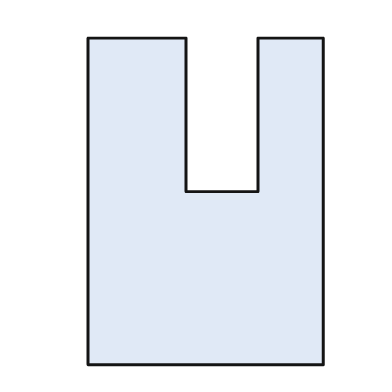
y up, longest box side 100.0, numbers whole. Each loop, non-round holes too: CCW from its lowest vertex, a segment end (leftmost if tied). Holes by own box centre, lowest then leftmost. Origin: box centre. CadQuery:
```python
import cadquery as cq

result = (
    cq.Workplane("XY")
    .moveTo(-36.0, -50.0)
    .lineTo(36.0, -50.0)
    .lineTo(36.0, 50.0)
    .lineTo(16.0, 50.0)
    .lineTo(16.0, 3.0)
    .lineTo(-6.0, 3.0)
    .lineTo(-6.0, 50.0)
    .lineTo(-36.0, 50.0)
    .close()
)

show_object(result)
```